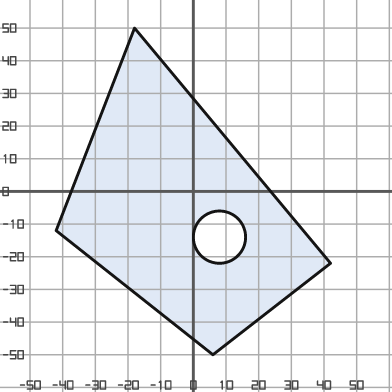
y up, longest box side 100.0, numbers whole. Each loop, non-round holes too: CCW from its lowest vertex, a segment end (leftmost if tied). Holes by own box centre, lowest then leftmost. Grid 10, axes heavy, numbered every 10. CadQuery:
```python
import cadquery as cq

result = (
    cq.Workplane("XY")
    .moveTo(6.0, -50.0)
    .lineTo(42.0, -22.0)
    .lineTo(-18.0, 50.0)
    .lineTo(-42.0, -12.0)
    .close()
    .moveTo(8.0, -14.0)
    .circle(8.0)
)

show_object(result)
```